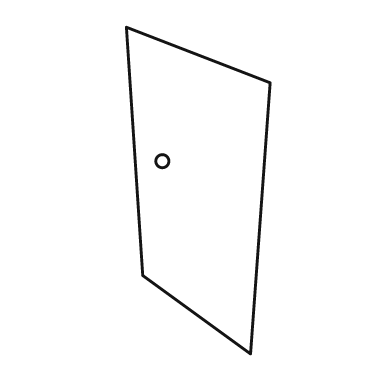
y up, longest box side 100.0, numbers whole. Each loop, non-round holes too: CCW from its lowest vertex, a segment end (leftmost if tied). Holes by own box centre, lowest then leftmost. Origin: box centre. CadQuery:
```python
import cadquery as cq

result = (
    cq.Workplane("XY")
    .moveTo(16.0, -50.0)
    .lineTo(22.0, 33.0)
    .lineTo(-22.0, 50.0)
    .lineTo(-17.0, -26.0)
    .close()
    .moveTo(-11.0, 9.0)
    .circle(2.0)
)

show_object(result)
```